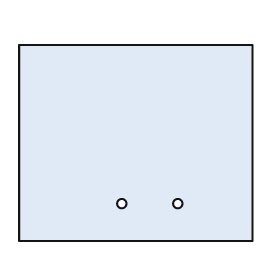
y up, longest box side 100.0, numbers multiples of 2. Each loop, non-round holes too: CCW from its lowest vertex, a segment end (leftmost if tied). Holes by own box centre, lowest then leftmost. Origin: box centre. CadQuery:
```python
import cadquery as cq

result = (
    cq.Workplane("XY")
    .moveTo(-50.0, -42.0)
    .lineTo(50.0, -42.0)
    .lineTo(50.0, 42.0)
    .lineTo(-50.0, 42.0)
    .close()
    .moveTo(-6.0, -26.0)
    .circle(2.0)
    .moveTo(18.0, -26.0)
    .circle(2.0)
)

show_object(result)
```